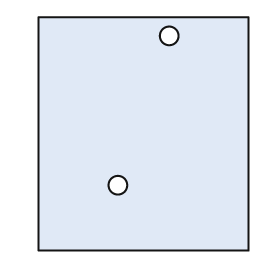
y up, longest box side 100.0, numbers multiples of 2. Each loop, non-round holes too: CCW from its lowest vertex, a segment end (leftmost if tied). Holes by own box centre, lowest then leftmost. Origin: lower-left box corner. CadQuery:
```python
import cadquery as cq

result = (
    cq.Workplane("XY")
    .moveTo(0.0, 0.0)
    .lineTo(90.0, 0.0)
    .lineTo(90.0, 100.0)
    .lineTo(0.0, 100.0)
    .close()
    .moveTo(34.0, 28.0)
    .circle(4.0)
    .moveTo(56.0, 92.0)
    .circle(4.0)
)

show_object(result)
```